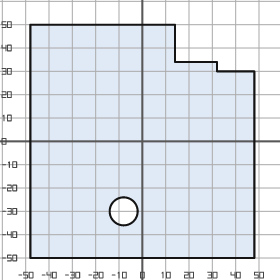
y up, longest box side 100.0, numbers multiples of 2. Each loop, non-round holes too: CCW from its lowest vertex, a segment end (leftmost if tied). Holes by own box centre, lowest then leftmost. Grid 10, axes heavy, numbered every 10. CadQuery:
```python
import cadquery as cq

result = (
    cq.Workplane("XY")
    .moveTo(-48.0, -50.0)
    .lineTo(48.0, -50.0)
    .lineTo(48.0, 30.0)
    .lineTo(32.0, 30.0)
    .lineTo(32.0, 34.0)
    .lineTo(14.0, 34.0)
    .lineTo(14.0, 50.0)
    .lineTo(-48.0, 50.0)
    .close()
    .moveTo(-8.0, -30.0)
    .circle(6.0)
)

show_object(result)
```